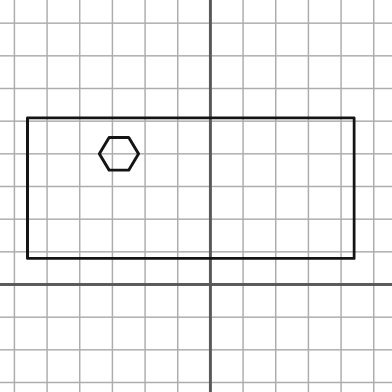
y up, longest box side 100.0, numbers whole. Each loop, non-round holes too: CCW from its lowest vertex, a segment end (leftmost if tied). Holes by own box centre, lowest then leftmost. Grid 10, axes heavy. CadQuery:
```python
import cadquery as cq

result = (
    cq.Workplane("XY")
    .moveTo(-56.0, 8.0)
    .lineTo(44.0, 8.0)
    .lineTo(44.0, 51.0)
    .lineTo(-56.0, 51.0)
    .close()
    .moveTo(-31.0, 35.0)
    .lineTo(-25.0, 35.0)
    .lineTo(-22.0, 40.0)
    .lineTo(-25.0, 45.0)
    .lineTo(-31.0, 45.0)
    .lineTo(-34.0, 40.0)
    .close()
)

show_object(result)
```